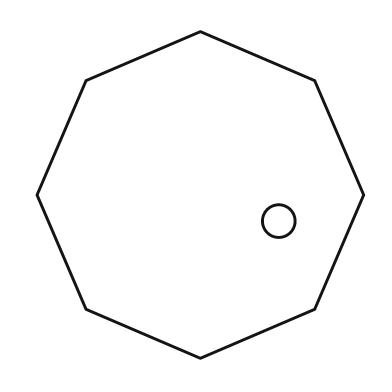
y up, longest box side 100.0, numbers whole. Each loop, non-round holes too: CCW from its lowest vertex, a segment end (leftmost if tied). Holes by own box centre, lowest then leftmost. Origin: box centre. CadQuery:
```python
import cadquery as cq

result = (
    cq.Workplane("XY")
    .moveTo(0.0, -50.0)
    .lineTo(35.0, -35.0)
    .lineTo(50.0, 0.0)
    .lineTo(35.0, 35.0)
    .lineTo(0.0, 50.0)
    .lineTo(-35.0, 35.0)
    .lineTo(-50.0, 0.0)
    .lineTo(-35.0, -35.0)
    .close()
    .moveTo(24.0, -8.0)
    .circle(5.0)
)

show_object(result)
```